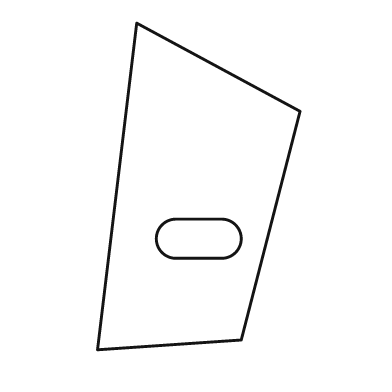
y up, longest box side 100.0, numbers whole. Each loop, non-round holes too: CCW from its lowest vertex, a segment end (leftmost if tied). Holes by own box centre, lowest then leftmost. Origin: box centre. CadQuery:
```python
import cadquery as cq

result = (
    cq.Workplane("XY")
    .moveTo(-31.0, -50.0)
    .lineTo(13.0, -47.0)
    .lineTo(31.0, 23.0)
    .lineTo(-19.0, 50.0)
    .close()
    .moveTo(-7.0, -22.0)
    .lineTo(7.0, -22.0)
    .threePointArc((13.0, -16.0), (7.0, -10.0))
    .lineTo(-7.0, -10.0)
    .threePointArc((-13.0, -16.0), (-7.0, -22.0))
    .close()
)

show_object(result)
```